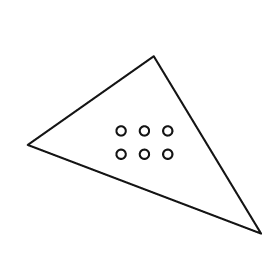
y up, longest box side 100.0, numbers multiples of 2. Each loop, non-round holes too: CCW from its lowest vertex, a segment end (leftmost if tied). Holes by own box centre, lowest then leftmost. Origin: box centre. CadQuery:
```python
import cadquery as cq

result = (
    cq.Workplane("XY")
    .moveTo(50.0, -38.0)
    .lineTo(4.0, 38.0)
    .lineTo(-50.0, 0.0)
    .close()
    .moveTo(-10.0, -4.0)
    .circle(2.0)
    .moveTo(0.0, -4.0)
    .circle(2.0)
    .moveTo(10.0, -4.0)
    .circle(2.0)
    .moveTo(-10.0, 6.0)
    .circle(2.0)
    .moveTo(0.0, 6.0)
    .circle(2.0)
    .moveTo(10.0, 6.0)
    .circle(2.0)
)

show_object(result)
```